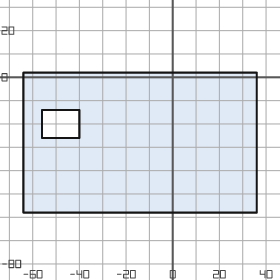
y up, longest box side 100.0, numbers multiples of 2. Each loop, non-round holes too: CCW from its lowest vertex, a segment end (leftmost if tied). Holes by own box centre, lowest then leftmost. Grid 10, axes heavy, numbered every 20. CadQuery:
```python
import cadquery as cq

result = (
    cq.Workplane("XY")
    .moveTo(-64.0, -58.0)
    .lineTo(36.0, -58.0)
    .lineTo(36.0, 2.0)
    .lineTo(-64.0, 2.0)
    .close()
    .moveTo(-56.0, -26.0)
    .lineTo(-40.0, -26.0)
    .lineTo(-40.0, -14.0)
    .lineTo(-56.0, -14.0)
    .close()
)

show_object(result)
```